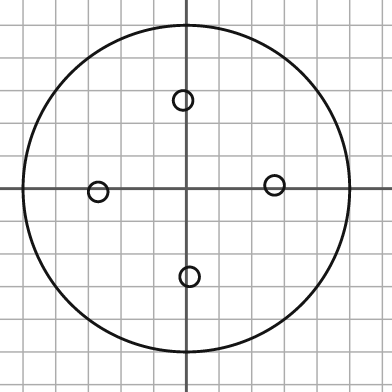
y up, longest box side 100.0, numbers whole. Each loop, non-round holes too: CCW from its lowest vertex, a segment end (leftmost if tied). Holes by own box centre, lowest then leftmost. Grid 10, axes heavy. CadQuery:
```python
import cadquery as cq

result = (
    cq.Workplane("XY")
    .moveTo(0.0, 0.0)
    .circle(50.0)
    .moveTo(1.0, -27.0)
    .circle(3.0)
    .moveTo(-27.0, -1.0)
    .circle(3.0)
    .moveTo(27.0, 1.0)
    .circle(3.0)
    .moveTo(-1.0, 27.0)
    .circle(3.0)
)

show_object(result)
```